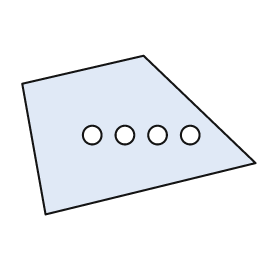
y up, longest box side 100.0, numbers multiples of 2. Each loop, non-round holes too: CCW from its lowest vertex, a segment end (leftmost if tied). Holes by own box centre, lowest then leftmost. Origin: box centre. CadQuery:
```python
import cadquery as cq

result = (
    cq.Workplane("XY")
    .moveTo(-40.0, -34.0)
    .lineTo(50.0, -12.0)
    .lineTo(2.0, 34.0)
    .lineTo(-50.0, 22.0)
    .close()
    .moveTo(-20.0, 0.0)
    .circle(4.0)
    .moveTo(-6.0, 0.0)
    .circle(4.0)
    .moveTo(8.0, 0.0)
    .circle(4.0)
    .moveTo(22.0, 0.0)
    .circle(4.0)
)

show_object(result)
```